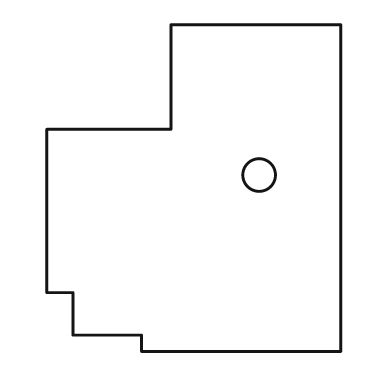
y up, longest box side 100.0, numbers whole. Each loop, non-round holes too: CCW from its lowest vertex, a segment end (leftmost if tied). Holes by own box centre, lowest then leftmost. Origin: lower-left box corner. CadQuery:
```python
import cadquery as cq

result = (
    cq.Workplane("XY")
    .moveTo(29.0, 0.0)
    .lineTo(90.0, 0.0)
    .lineTo(90.0, 100.0)
    .lineTo(38.0, 100.0)
    .lineTo(38.0, 68.0)
    .lineTo(0.0, 68.0)
    .lineTo(0.0, 18.0)
    .lineTo(8.0, 18.0)
    .lineTo(8.0, 5.0)
    .lineTo(29.0, 5.0)
    .close()
    .moveTo(65.0, 54.0)
    .circle(5.0)
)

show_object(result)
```